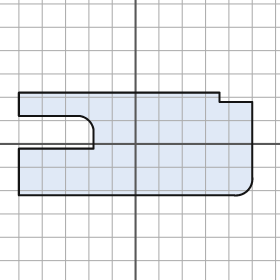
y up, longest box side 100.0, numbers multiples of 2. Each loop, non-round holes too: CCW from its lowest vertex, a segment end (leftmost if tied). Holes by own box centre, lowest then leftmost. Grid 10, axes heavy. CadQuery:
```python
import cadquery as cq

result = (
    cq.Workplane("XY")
    .moveTo(-50.0, -22.0)
    .lineTo(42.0, -22.0)
    .threePointArc((48.0, -20.0), (50.0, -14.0))
    .lineTo(50.0, 18.0)
    .lineTo(36.0, 18.0)
    .lineTo(36.0, 22.0)
    .lineTo(-50.0, 22.0)
    .lineTo(-50.0, 12.0)
    .lineTo(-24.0, 12.0)
    .threePointArc((-20.0, 10.0), (-18.0, 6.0))
    .lineTo(-18.0, -2.0)
    .lineTo(-50.0, -2.0)
    .close()
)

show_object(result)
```